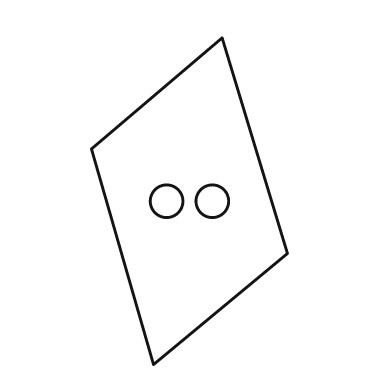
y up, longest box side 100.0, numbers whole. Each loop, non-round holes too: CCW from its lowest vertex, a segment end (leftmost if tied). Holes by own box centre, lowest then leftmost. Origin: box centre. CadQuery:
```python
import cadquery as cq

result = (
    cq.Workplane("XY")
    .moveTo(-11.0, -50.0)
    .lineTo(30.0, -16.0)
    .lineTo(10.0, 50.0)
    .lineTo(-30.0, 16.0)
    .close()
    .moveTo(-7.0, 0.0)
    .circle(5.0)
    .moveTo(7.0, 0.0)
    .circle(5.0)
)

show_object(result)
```